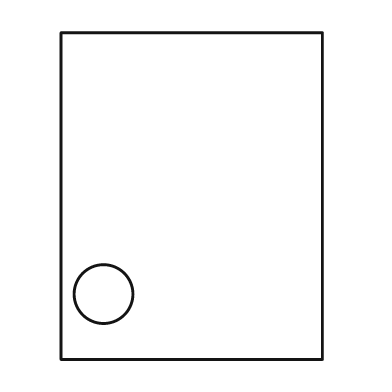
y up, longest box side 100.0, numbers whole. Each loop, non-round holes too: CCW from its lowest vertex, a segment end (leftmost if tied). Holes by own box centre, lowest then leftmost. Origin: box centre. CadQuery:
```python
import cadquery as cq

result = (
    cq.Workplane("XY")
    .moveTo(-40.0, -50.0)
    .lineTo(40.0, -50.0)
    .lineTo(40.0, 50.0)
    .lineTo(-40.0, 50.0)
    .close()
    .moveTo(-27.0, -30.0)
    .circle(9.0)
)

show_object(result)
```